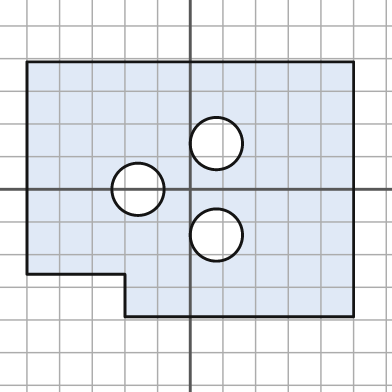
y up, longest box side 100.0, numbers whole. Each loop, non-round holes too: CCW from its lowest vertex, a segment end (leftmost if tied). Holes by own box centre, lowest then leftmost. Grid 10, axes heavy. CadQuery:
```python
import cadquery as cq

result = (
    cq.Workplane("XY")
    .moveTo(-20.0, -39.0)
    .lineTo(50.0, -39.0)
    .lineTo(50.0, 39.0)
    .lineTo(-50.0, 39.0)
    .lineTo(-50.0, -26.0)
    .lineTo(-20.0, -26.0)
    .close()
    .moveTo(8.0, -14.0)
    .circle(8.0)
    .moveTo(-16.0, 0.0)
    .circle(8.0)
    .moveTo(8.0, 14.0)
    .circle(8.0)
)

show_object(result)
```